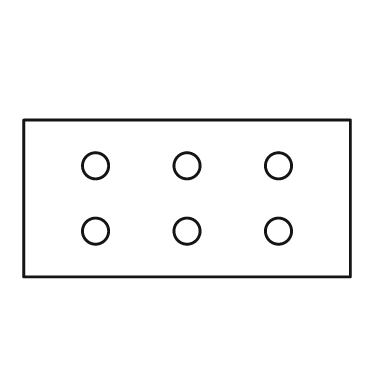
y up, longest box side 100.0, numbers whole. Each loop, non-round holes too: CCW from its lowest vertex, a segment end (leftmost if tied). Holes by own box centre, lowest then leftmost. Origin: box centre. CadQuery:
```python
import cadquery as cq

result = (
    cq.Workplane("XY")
    .moveTo(-50.0, -24.0)
    .lineTo(50.0, -24.0)
    .lineTo(50.0, 24.0)
    .lineTo(-50.0, 24.0)
    .close()
    .moveTo(-28.0, -10.0)
    .circle(4.0)
    .moveTo(0.0, -10.0)
    .circle(4.0)
    .moveTo(28.0, -10.0)
    .circle(4.0)
    .moveTo(-28.0, 10.0)
    .circle(4.0)
    .moveTo(0.0, 10.0)
    .circle(4.0)
    .moveTo(28.0, 10.0)
    .circle(4.0)
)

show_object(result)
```